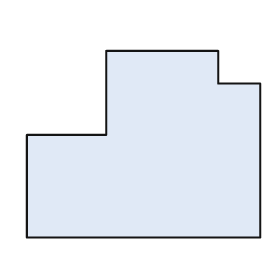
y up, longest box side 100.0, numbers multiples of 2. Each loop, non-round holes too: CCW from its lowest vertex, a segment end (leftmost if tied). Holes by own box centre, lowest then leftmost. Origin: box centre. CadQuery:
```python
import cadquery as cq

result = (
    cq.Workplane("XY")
    .moveTo(-50.0, -40.0)
    .lineTo(50.0, -40.0)
    .lineTo(50.0, 26.0)
    .lineTo(32.0, 26.0)
    .lineTo(32.0, 40.0)
    .lineTo(-16.0, 40.0)
    .lineTo(-16.0, 4.0)
    .lineTo(-50.0, 4.0)
    .close()
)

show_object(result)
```